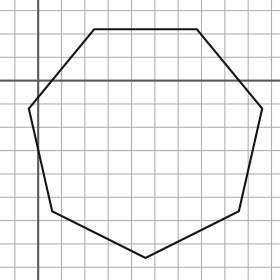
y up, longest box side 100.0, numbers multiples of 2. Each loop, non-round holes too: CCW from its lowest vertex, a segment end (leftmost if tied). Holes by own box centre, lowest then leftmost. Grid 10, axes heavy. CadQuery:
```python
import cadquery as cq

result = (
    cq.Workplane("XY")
    .moveTo(46.0, -76.0)
    .lineTo(86.0, -56.0)
    .lineTo(96.0, -12.0)
    .lineTo(68.0, 22.0)
    .lineTo(24.0, 22.0)
    .lineTo(-4.0, -12.0)
    .lineTo(6.0, -56.0)
    .close()
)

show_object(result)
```